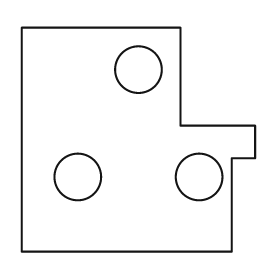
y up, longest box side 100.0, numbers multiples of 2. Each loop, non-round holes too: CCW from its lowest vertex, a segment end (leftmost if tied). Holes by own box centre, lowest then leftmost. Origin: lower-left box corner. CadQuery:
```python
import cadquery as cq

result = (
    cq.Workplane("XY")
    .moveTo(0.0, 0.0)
    .lineTo(90.0, 0.0)
    .lineTo(90.0, 40.0)
    .lineTo(100.0, 40.0)
    .lineTo(100.0, 54.0)
    .lineTo(68.0, 54.0)
    .lineTo(68.0, 96.0)
    .lineTo(0.0, 96.0)
    .close()
    .moveTo(24.0, 32.0)
    .circle(10.0)
    .moveTo(76.0, 32.0)
    .circle(10.0)
    .moveTo(50.0, 78.0)
    .circle(10.0)
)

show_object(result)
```